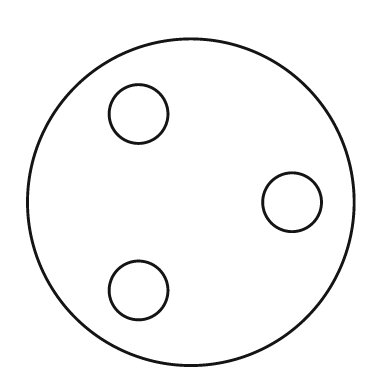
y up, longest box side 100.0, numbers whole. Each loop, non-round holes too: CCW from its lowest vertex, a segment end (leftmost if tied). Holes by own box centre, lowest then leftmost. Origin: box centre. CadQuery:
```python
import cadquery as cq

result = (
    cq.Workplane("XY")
    .moveTo(0.0, 0.0)
    .circle(50.0)
    .moveTo(-16.0, -27.0)
    .circle(9.0)
    .moveTo(31.0, 0.0)
    .circle(9.0)
    .moveTo(-16.0, 27.0)
    .circle(9.0)
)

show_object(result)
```